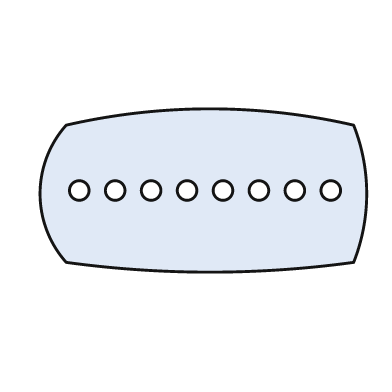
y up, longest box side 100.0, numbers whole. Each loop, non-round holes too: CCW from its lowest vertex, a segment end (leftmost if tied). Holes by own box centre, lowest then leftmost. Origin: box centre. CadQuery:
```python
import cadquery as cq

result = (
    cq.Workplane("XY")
    .moveTo(-42.0, -22.0)
    .threePointArc((2.0, -25.0), (46.0, -22.0))
    .threePointArc((50.0, -1.0), (46.0, 20.0))
    .threePointArc((2.0, 25.0), (-42.0, 20.0))
    .threePointArc((-50.0, -1.0), (-42.0, -22.0))
    .close()
    .moveTo(-38.0, 0.0)
    .circle(3.0)
    .moveTo(-27.0, 0.0)
    .circle(3.0)
    .moveTo(-16.0, 0.0)
    .circle(3.0)
    .moveTo(-5.0, 0.0)
    .circle(3.0)
    .moveTo(6.0, 0.0)
    .circle(3.0)
    .moveTo(17.0, 0.0)
    .circle(3.0)
    .moveTo(28.0, 0.0)
    .circle(3.0)
    .moveTo(39.0, 0.0)
    .circle(3.0)
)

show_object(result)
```